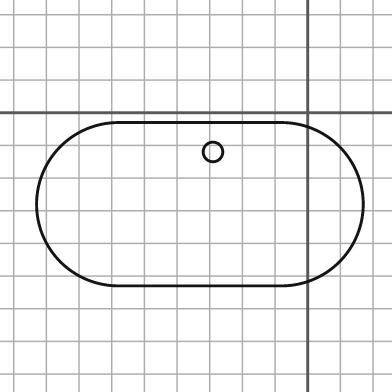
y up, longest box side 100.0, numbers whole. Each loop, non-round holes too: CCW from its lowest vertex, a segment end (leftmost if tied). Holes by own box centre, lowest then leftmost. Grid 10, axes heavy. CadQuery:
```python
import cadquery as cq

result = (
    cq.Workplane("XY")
    .moveTo(-58.0, -53.0)
    .lineTo(-8.0, -53.0)
    .threePointArc((17.0, -28.0), (-8.0, -3.0))
    .lineTo(-58.0, -3.0)
    .threePointArc((-83.0, -28.0), (-58.0, -53.0))
    .close()
    .moveTo(-29.0, -12.0)
    .circle(3.0)
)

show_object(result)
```